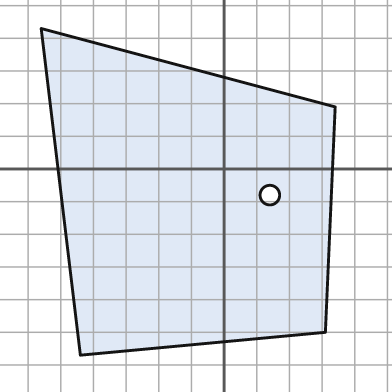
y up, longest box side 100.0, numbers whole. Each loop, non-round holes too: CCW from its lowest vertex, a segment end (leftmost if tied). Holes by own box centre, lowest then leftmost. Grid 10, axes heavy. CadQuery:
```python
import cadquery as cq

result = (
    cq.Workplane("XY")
    .moveTo(-44.0, -57.0)
    .lineTo(31.0, -50.0)
    .lineTo(34.0, 19.0)
    .lineTo(-56.0, 43.0)
    .close()
    .moveTo(14.0, -8.0)
    .circle(3.0)
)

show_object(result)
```